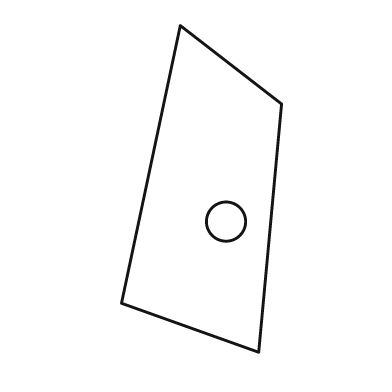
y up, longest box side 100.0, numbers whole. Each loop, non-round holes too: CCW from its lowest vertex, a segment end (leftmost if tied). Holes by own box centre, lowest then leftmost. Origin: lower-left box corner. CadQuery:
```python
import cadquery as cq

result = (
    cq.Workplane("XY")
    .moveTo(42.0, 0.0)
    .lineTo(49.0, 76.0)
    .lineTo(18.0, 100.0)
    .lineTo(0.0, 15.0)
    .close()
    .moveTo(32.0, 40.0)
    .circle(6.0)
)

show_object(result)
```